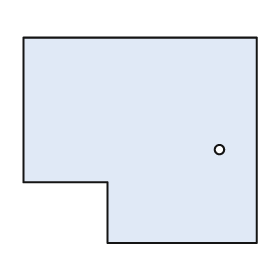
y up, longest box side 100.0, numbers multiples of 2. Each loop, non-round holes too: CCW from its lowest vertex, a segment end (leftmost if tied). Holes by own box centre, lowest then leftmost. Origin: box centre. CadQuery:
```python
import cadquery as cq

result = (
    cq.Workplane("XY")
    .moveTo(-14.0, -44.0)
    .lineTo(50.0, -44.0)
    .lineTo(50.0, 44.0)
    .lineTo(-50.0, 44.0)
    .lineTo(-50.0, -18.0)
    .lineTo(-14.0, -18.0)
    .close()
    .moveTo(34.0, -4.0)
    .circle(2.0)
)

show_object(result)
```